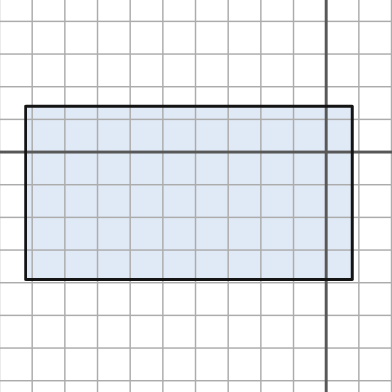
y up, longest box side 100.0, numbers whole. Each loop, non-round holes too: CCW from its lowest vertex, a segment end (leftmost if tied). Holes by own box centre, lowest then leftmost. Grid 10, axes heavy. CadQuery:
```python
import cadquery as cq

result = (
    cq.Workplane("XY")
    .moveTo(-92.0, -39.0)
    .lineTo(8.0, -39.0)
    .lineTo(8.0, 14.0)
    .lineTo(-92.0, 14.0)
    .close()
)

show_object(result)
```